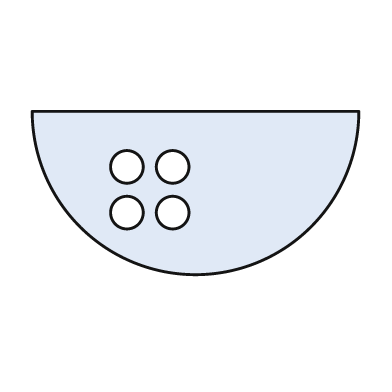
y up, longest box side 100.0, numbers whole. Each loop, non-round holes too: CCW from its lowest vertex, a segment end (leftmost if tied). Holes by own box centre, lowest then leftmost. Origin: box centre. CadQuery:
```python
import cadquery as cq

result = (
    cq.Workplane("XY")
    .moveTo(-50.0, 25.0)
    .threePointArc((0.0, -25.0), (50.0, 25.0))
    .close()
    .moveTo(-21.0, -6.0)
    .circle(5.0)
    .moveTo(-7.0, -6.0)
    .circle(5.0)
    .moveTo(-21.0, 8.0)
    .circle(5.0)
    .moveTo(-7.0, 8.0)
    .circle(5.0)
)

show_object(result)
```